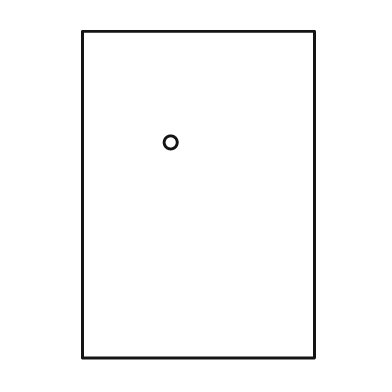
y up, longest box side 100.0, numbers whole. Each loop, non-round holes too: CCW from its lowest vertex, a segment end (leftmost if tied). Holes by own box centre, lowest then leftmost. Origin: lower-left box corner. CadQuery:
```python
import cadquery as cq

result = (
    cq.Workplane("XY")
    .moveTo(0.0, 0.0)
    .lineTo(71.0, 0.0)
    .lineTo(71.0, 100.0)
    .lineTo(0.0, 100.0)
    .close()
    .moveTo(27.0, 66.0)
    .circle(2.0)
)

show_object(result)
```